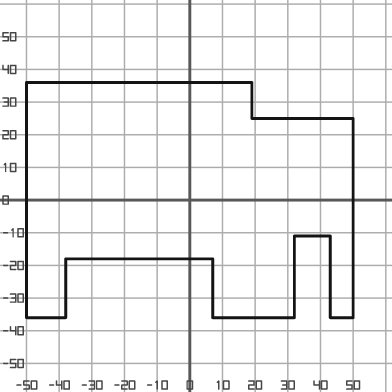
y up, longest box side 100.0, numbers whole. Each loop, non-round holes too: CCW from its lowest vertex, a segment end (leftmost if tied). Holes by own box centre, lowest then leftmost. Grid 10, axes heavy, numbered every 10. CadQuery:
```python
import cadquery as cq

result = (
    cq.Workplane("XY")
    .moveTo(-50.0, -36.0)
    .lineTo(-38.0, -36.0)
    .lineTo(-38.0, -18.0)
    .lineTo(7.0, -18.0)
    .lineTo(7.0, -36.0)
    .lineTo(32.0, -36.0)
    .lineTo(32.0, -11.0)
    .lineTo(43.0, -11.0)
    .lineTo(43.0, -36.0)
    .lineTo(50.0, -36.0)
    .lineTo(50.0, 25.0)
    .lineTo(19.0, 25.0)
    .lineTo(19.0, 36.0)
    .lineTo(-50.0, 36.0)
    .close()
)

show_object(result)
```